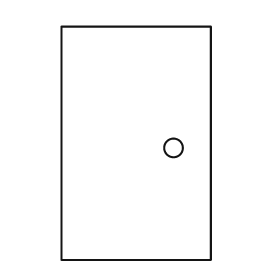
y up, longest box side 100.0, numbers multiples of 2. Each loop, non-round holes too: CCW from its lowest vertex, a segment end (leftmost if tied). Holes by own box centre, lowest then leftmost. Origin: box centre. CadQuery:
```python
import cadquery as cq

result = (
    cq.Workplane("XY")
    .moveTo(-32.0, -50.0)
    .lineTo(32.0, -50.0)
    .lineTo(32.0, 50.0)
    .lineTo(-32.0, 50.0)
    .close()
    .moveTo(16.0, -2.0)
    .circle(4.0)
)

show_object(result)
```